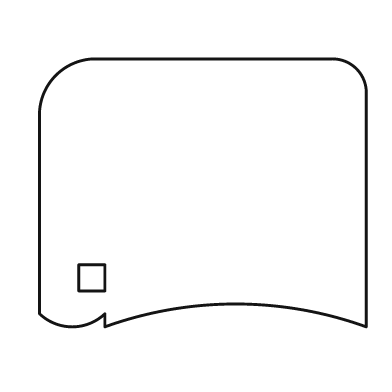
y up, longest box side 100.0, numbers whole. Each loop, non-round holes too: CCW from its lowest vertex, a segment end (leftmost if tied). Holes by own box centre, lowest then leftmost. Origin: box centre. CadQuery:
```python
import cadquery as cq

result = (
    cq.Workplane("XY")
    .moveTo(-30.0, -41.0)
    .threePointArc((10.0, -34.0), (50.0, -41.0))
    .lineTo(50.0, 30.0)
    .threePointArc((47.0, 38.0), (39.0, 41.0))
    .lineTo(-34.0, 41.0)
    .threePointArc((-45.0, 36.0), (-50.0, 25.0))
    .lineTo(-50.0, -37.0)
    .threePointArc((-40.0, -41.0), (-30.0, -37.0))
    .close()
    .moveTo(-38.0, -30.0)
    .lineTo(-30.0, -30.0)
    .lineTo(-30.0, -22.0)
    .lineTo(-38.0, -22.0)
    .close()
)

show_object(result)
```